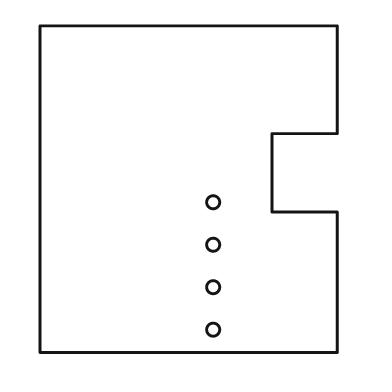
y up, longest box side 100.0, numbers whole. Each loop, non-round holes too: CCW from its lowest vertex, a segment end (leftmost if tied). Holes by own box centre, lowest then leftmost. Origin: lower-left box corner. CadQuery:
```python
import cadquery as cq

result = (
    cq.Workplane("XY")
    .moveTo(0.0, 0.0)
    .lineTo(91.0, 0.0)
    .lineTo(91.0, 43.0)
    .lineTo(71.0, 43.0)
    .lineTo(71.0, 67.0)
    .lineTo(91.0, 67.0)
    .lineTo(91.0, 100.0)
    .lineTo(0.0, 100.0)
    .close()
    .moveTo(53.0, 7.0)
    .circle(2.0)
    .moveTo(53.0, 20.0)
    .circle(2.0)
    .moveTo(53.0, 33.0)
    .circle(2.0)
    .moveTo(53.0, 46.0)
    .circle(2.0)
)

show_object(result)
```